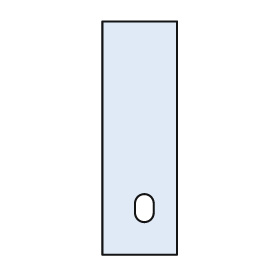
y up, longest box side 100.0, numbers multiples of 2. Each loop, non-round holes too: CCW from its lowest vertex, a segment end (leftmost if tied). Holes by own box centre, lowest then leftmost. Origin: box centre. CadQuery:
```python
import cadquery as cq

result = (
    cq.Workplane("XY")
    .moveTo(-16.0, -50.0)
    .lineTo(16.0, -50.0)
    .lineTo(16.0, 50.0)
    .lineTo(-16.0, 50.0)
    .close()
    .moveTo(-2.0, -32.0)
    .threePointArc((2.0, -36.0), (6.0, -32.0))
    .lineTo(6.0, -28.0)
    .threePointArc((2.0, -24.0), (-2.0, -28.0))
    .close()
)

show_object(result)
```